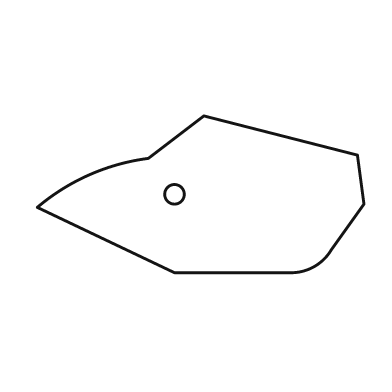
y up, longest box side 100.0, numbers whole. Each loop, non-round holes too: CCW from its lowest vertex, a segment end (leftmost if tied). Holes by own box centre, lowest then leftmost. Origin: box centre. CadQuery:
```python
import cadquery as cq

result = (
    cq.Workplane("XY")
    .moveTo(-8.0, -24.0)
    .lineTo(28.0, -24.0)
    .threePointArc((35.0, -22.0), (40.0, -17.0))
    .lineTo(50.0, -3.0)
    .lineTo(48.0, 12.0)
    .lineTo(1.0, 24.0)
    .lineTo(-16.0, 11.0)
    .threePointArc((-34.0, 6.0), (-50.0, -4.0))
    .close()
    .moveTo(-8.0, 0.0)
    .circle(3.0)
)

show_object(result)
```